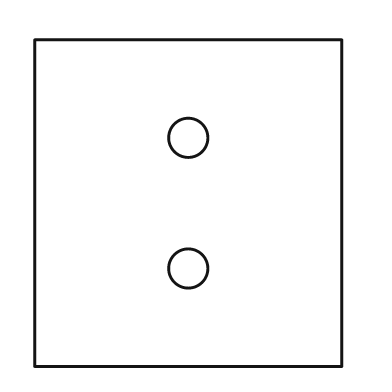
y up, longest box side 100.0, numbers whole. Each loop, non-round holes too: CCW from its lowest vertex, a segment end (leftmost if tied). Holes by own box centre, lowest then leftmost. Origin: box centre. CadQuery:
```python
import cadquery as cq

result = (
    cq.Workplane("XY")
    .moveTo(-47.0, -50.0)
    .lineTo(47.0, -50.0)
    .lineTo(47.0, 50.0)
    .lineTo(-47.0, 50.0)
    .close()
    .moveTo(0.0, -20.0)
    .circle(6.0)
    .moveTo(0.0, 20.0)
    .circle(6.0)
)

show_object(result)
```